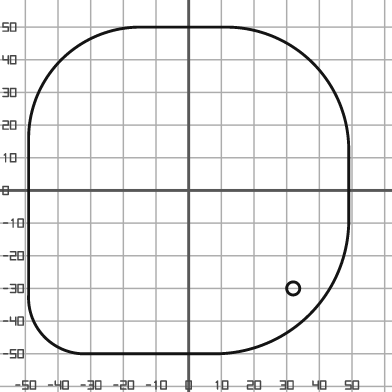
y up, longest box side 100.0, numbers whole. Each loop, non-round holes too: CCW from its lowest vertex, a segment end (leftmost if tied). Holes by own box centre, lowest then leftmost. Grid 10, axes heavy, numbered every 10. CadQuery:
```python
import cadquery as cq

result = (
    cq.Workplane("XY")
    .moveTo(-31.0, -50.0)
    .lineTo(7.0, -50.0)
    .threePointArc((37.0, -38.0), (49.0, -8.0))
    .lineTo(49.0, 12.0)
    .threePointArc((38.0, 39.0), (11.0, 50.0))
    .lineTo(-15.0, 50.0)
    .threePointArc((-39.0, 40.0), (-49.0, 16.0))
    .lineTo(-49.0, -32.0)
    .threePointArc((-44.0, -45.0), (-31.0, -50.0))
    .close()
    .moveTo(32.0, -30.0)
    .circle(2.0)
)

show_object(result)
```